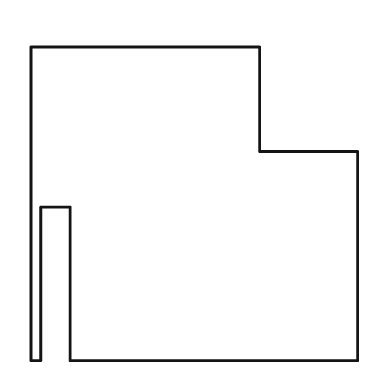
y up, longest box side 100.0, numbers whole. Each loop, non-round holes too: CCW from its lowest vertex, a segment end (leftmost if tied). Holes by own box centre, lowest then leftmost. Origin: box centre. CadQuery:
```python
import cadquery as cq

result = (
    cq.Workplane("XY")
    .moveTo(-50.0, -48.0)
    .lineTo(-47.0, -48.0)
    .lineTo(-47.0, -1.0)
    .lineTo(-38.0, -1.0)
    .lineTo(-38.0, -48.0)
    .lineTo(50.0, -48.0)
    .lineTo(50.0, 16.0)
    .lineTo(20.0, 16.0)
    .lineTo(20.0, 48.0)
    .lineTo(-50.0, 48.0)
    .close()
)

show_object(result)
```